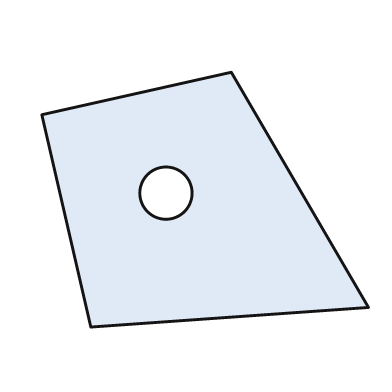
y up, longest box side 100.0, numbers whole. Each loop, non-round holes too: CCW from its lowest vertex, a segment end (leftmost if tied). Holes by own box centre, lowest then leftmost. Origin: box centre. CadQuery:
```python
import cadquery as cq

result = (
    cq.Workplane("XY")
    .moveTo(-35.0, -39.0)
    .lineTo(50.0, -33.0)
    .lineTo(8.0, 39.0)
    .lineTo(-50.0, 26.0)
    .close()
    .moveTo(-12.0, 2.0)
    .circle(8.0)
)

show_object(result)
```